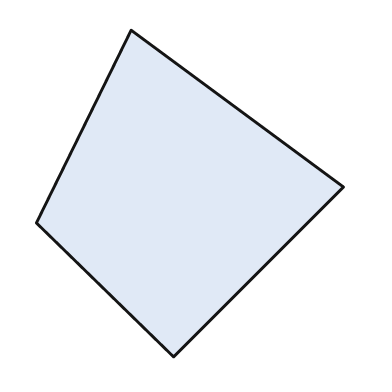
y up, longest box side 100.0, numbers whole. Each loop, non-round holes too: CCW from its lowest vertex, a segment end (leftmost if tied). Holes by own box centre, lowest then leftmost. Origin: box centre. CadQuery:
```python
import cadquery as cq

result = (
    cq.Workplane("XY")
    .moveTo(-5.0, -50.0)
    .lineTo(47.0, 2.0)
    .lineTo(-18.0, 50.0)
    .lineTo(-47.0, -9.0)
    .close()
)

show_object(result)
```